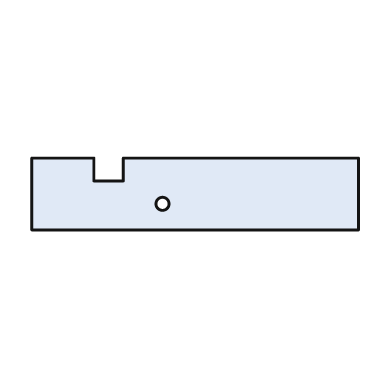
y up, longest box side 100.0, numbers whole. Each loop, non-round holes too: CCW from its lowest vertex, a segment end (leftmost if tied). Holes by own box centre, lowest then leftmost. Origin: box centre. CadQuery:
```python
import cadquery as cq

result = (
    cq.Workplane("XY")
    .moveTo(-50.0, -11.0)
    .lineTo(50.0, -11.0)
    .lineTo(50.0, 11.0)
    .lineTo(-22.0, 11.0)
    .lineTo(-22.0, 4.0)
    .lineTo(-31.0, 4.0)
    .lineTo(-31.0, 11.0)
    .lineTo(-50.0, 11.0)
    .close()
    .moveTo(-10.0, -3.0)
    .circle(2.0)
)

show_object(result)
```